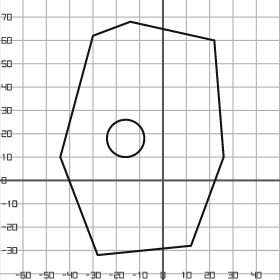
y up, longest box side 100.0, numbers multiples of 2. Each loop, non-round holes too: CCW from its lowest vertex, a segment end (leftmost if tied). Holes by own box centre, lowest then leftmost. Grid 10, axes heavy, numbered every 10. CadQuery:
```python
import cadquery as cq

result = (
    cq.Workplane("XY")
    .moveTo(-28.0, -32.0)
    .lineTo(12.0, -28.0)
    .lineTo(26.0, 10.0)
    .lineTo(22.0, 60.0)
    .lineTo(-14.0, 68.0)
    .lineTo(-30.0, 62.0)
    .lineTo(-44.0, 10.0)
    .close()
    .moveTo(-16.0, 18.0)
    .circle(8.0)
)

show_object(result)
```